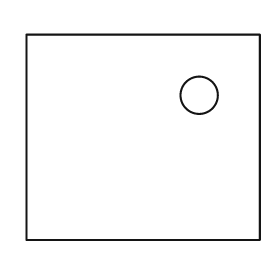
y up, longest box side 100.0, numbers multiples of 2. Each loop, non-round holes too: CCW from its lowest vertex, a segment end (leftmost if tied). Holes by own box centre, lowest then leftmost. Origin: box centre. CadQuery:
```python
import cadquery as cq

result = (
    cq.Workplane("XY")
    .moveTo(-50.0, -44.0)
    .lineTo(50.0, -44.0)
    .lineTo(50.0, 44.0)
    .lineTo(-50.0, 44.0)
    .close()
    .moveTo(24.0, 18.0)
    .circle(8.0)
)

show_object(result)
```